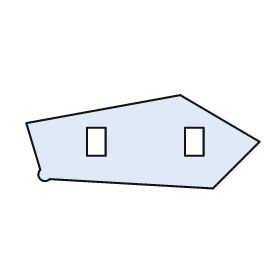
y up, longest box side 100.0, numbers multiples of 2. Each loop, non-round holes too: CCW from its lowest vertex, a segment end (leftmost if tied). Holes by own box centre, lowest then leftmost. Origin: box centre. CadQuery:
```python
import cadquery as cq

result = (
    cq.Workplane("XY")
    .moveTo(30.0, -20.0)
    .lineTo(50.0, 0.0)
    .lineTo(16.0, 20.0)
    .lineTo(-50.0, 8.0)
    .lineTo(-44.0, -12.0)
    .threePointArc((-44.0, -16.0), (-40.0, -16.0))
    .close()
    .moveTo(-24.0, -6.0)
    .lineTo(-16.0, -6.0)
    .lineTo(-16.0, 6.0)
    .lineTo(-24.0, 6.0)
    .close()
    .moveTo(18.0, -6.0)
    .lineTo(26.0, -6.0)
    .lineTo(26.0, 6.0)
    .lineTo(18.0, 6.0)
    .close()
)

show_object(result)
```